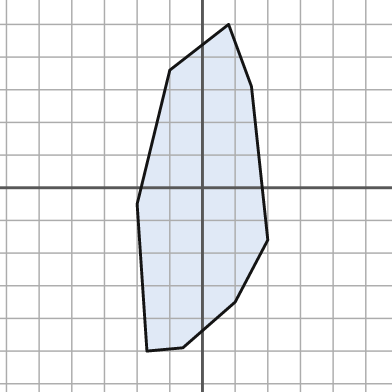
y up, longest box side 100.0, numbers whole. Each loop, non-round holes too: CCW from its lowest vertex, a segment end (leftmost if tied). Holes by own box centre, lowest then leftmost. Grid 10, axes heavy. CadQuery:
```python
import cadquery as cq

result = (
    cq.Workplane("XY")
    .moveTo(-17.0, -50.0)
    .lineTo(-6.0, -49.0)
    .lineTo(10.0, -35.0)
    .lineTo(20.0, -16.0)
    .lineTo(15.0, 31.0)
    .lineTo(8.0, 50.0)
    .lineTo(-10.0, 36.0)
    .lineTo(-20.0, -5.0)
    .close()
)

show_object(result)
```